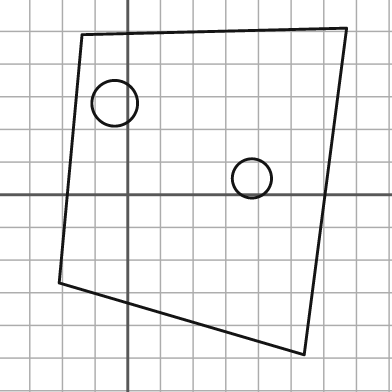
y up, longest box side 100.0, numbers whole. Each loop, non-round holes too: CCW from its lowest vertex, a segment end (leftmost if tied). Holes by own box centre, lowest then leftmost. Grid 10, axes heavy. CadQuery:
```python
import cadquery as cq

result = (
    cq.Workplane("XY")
    .moveTo(54.0, -49.0)
    .lineTo(67.0, 51.0)
    .lineTo(-14.0, 49.0)
    .lineTo(-21.0, -27.0)
    .close()
    .moveTo(38.0, 5.0)
    .circle(6.0)
    .moveTo(-4.0, 28.0)
    .circle(7.0)
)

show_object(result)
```